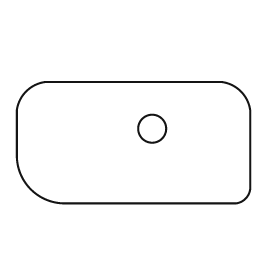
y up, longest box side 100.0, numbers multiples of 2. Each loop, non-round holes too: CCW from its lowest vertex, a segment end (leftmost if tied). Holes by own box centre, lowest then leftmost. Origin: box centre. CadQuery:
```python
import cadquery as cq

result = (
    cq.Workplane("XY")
    .moveTo(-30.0, -26.0)
    .lineTo(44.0, -26.0)
    .threePointArc((48.0, -24.0), (50.0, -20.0))
    .lineTo(50.0, 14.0)
    .threePointArc((46.0, 22.0), (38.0, 26.0))
    .lineTo(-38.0, 26.0)
    .threePointArc((-46.0, 22.0), (-50.0, 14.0))
    .lineTo(-50.0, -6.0)
    .threePointArc((-44.0, -20.0), (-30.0, -26.0))
    .close()
    .moveTo(8.0, 6.0)
    .circle(6.0)
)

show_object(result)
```